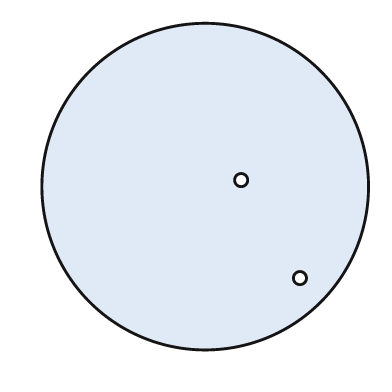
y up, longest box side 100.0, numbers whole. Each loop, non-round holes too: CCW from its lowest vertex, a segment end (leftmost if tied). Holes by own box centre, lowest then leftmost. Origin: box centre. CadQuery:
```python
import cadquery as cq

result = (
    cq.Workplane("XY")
    .moveTo(0.0, 0.0)
    .circle(50.0)
    .moveTo(29.0, -28.0)
    .circle(2.0)
    .moveTo(11.0, 2.0)
    .circle(2.0)
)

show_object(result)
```